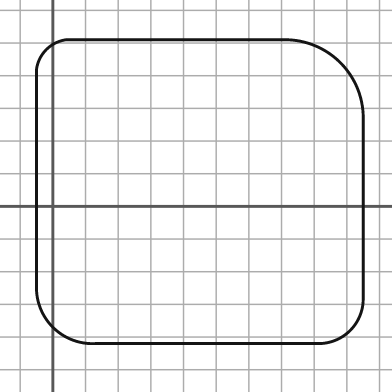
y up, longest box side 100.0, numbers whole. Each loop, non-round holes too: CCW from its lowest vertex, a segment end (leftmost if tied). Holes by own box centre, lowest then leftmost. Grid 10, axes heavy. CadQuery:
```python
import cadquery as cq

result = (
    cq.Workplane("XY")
    .moveTo(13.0, -42.0)
    .lineTo(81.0, -42.0)
    .threePointArc((91.0, -38.0), (95.0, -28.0))
    .lineTo(95.0, 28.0)
    .threePointArc((88.0, 44.0), (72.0, 51.0))
    .lineTo(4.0, 51.0)
    .threePointArc((-2.0, 48.0), (-5.0, 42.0))
    .lineTo(-5.0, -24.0)
    .threePointArc((0.0, -37.0), (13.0, -42.0))
    .close()
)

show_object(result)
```